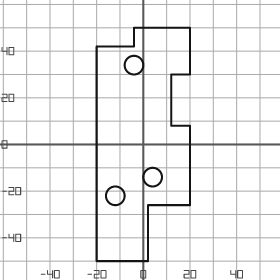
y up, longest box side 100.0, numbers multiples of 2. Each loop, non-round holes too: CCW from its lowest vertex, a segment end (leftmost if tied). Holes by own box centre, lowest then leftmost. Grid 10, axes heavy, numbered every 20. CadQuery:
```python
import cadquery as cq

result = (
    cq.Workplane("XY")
    .moveTo(-20.0, -50.0)
    .lineTo(2.0, -50.0)
    .lineTo(2.0, -26.0)
    .lineTo(20.0, -26.0)
    .lineTo(20.0, 8.0)
    .lineTo(12.0, 8.0)
    .lineTo(12.0, 30.0)
    .lineTo(20.0, 30.0)
    .lineTo(20.0, 50.0)
    .lineTo(-4.0, 50.0)
    .lineTo(-4.0, 42.0)
    .lineTo(-20.0, 42.0)
    .close()
    .moveTo(-12.0, -22.0)
    .circle(4.0)
    .moveTo(4.0, -14.0)
    .circle(4.0)
    .moveTo(-4.0, 34.0)
    .circle(4.0)
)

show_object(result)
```